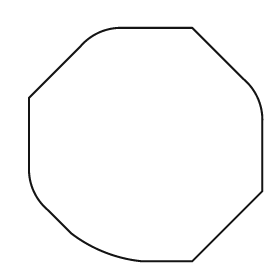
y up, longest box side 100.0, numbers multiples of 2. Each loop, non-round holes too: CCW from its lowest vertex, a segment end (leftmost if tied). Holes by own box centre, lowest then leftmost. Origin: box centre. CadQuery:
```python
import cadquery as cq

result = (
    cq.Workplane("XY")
    .moveTo(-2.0, -50.0)
    .lineTo(20.0, -50.0)
    .lineTo(50.0, -20.0)
    .lineTo(50.0, 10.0)
    .threePointArc((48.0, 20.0), (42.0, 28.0))
    .lineTo(20.0, 50.0)
    .lineTo(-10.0, 50.0)
    .threePointArc((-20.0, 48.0), (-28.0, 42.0))
    .lineTo(-50.0, 20.0)
    .lineTo(-50.0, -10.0)
    .threePointArc((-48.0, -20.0), (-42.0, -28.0))
    .lineTo(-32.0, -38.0)
    .threePointArc((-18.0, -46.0), (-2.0, -50.0))
    .close()
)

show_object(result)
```